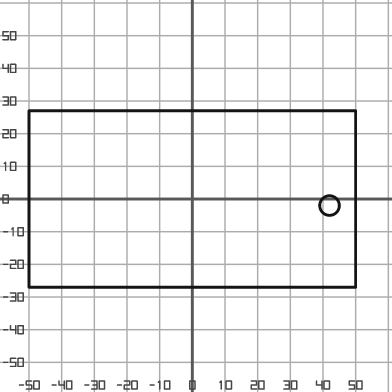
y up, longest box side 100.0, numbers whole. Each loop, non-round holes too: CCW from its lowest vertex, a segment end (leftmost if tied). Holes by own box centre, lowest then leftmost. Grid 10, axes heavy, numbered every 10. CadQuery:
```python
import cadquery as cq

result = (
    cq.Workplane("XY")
    .moveTo(-50.0, -27.0)
    .lineTo(50.0, -27.0)
    .lineTo(50.0, 27.0)
    .lineTo(-50.0, 27.0)
    .close()
    .moveTo(42.0, -2.0)
    .circle(3.0)
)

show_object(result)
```